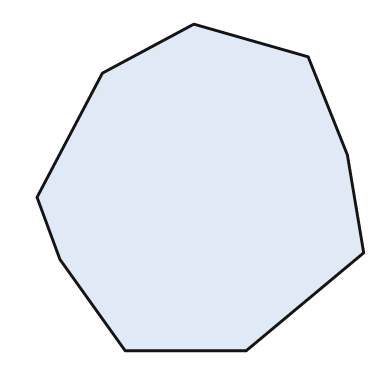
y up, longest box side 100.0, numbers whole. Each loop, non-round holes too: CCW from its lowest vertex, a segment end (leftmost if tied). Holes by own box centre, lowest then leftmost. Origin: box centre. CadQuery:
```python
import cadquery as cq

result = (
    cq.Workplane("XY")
    .moveTo(-23.0, -50.0)
    .lineTo(14.0, -50.0)
    .lineTo(50.0, -20.0)
    .lineTo(45.0, 10.0)
    .lineTo(33.0, 40.0)
    .lineTo(-2.0, 50.0)
    .lineTo(-30.0, 35.0)
    .lineTo(-50.0, -3.0)
    .lineTo(-43.0, -22.0)
    .close()
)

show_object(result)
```